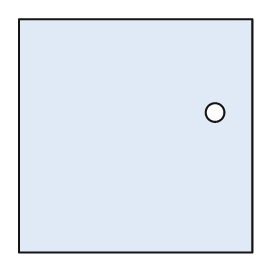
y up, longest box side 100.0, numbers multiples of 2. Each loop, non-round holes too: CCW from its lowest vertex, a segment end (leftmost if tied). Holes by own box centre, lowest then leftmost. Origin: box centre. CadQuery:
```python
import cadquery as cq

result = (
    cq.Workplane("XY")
    .moveTo(-50.0, -50.0)
    .lineTo(50.0, -50.0)
    .lineTo(50.0, 50.0)
    .lineTo(-50.0, 50.0)
    .close()
    .moveTo(34.0, 10.0)
    .circle(4.0)
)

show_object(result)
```